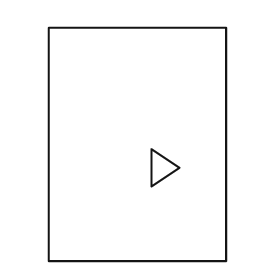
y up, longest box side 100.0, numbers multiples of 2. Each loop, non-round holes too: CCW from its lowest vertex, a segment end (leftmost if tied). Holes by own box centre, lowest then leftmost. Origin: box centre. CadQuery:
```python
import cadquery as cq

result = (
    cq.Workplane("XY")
    .moveTo(-38.0, -50.0)
    .lineTo(38.0, -50.0)
    .lineTo(38.0, 50.0)
    .lineTo(-38.0, 50.0)
    .close()
    .moveTo(6.0, -18.0)
    .lineTo(18.0, -10.0)
    .lineTo(6.0, -2.0)
    .close()
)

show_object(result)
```